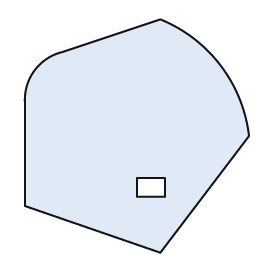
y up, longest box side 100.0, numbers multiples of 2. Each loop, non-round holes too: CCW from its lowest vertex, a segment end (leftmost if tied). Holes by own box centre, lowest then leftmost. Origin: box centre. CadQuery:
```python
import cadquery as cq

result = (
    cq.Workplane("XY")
    .moveTo(10.0, -50.0)
    .lineTo(48.0, 0.0)
    .threePointArc((36.0, 30.0), (10.0, 50.0))
    .lineTo(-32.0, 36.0)
    .threePointArc((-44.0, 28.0), (-48.0, 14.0))
    .lineTo(-48.0, -30.0)
    .close()
    .moveTo(0.0, -26.0)
    .lineTo(12.0, -26.0)
    .lineTo(12.0, -18.0)
    .lineTo(0.0, -18.0)
    .close()
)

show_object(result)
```